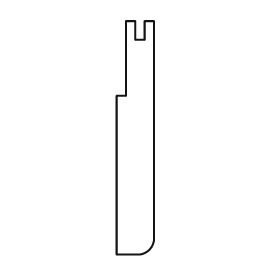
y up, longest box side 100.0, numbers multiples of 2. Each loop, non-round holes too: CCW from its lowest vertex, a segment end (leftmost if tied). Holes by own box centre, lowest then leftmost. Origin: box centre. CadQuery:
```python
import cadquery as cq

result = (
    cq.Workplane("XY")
    .moveTo(-8.0, -50.0)
    .lineTo(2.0, -50.0)
    .threePointArc((6.0, -48.0), (8.0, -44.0))
    .lineTo(8.0, 50.0)
    .lineTo(4.0, 50.0)
    .lineTo(4.0, 42.0)
    .lineTo(0.0, 42.0)
    .lineTo(0.0, 50.0)
    .lineTo(-4.0, 50.0)
    .lineTo(-4.0, 18.0)
    .lineTo(-8.0, 18.0)
    .close()
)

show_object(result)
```